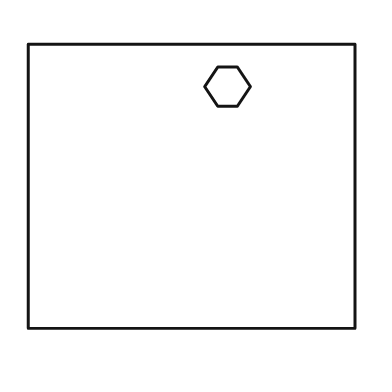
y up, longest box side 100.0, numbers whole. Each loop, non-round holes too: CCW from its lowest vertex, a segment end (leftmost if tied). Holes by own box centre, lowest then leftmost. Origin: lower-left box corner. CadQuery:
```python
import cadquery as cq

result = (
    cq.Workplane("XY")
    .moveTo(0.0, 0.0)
    .lineTo(100.0, 0.0)
    .lineTo(100.0, 87.0)
    .lineTo(0.0, 87.0)
    .close()
    .moveTo(58.0, 68.0)
    .lineTo(64.0, 68.0)
    .lineTo(68.0, 74.0)
    .lineTo(64.0, 80.0)
    .lineTo(58.0, 80.0)
    .lineTo(54.0, 74.0)
    .close()
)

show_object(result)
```